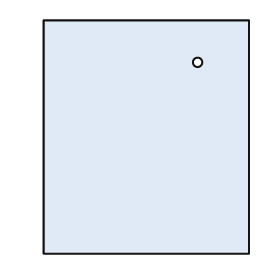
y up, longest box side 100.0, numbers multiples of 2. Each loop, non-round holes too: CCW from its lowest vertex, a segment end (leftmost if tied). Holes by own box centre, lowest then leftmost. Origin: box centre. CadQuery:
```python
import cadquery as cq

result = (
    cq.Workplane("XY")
    .moveTo(-44.0, -50.0)
    .lineTo(44.0, -50.0)
    .lineTo(44.0, 50.0)
    .lineTo(-44.0, 50.0)
    .close()
    .moveTo(22.0, 32.0)
    .circle(2.0)
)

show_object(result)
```